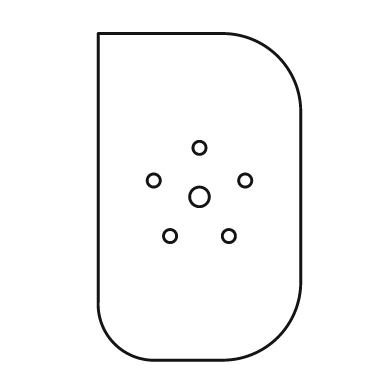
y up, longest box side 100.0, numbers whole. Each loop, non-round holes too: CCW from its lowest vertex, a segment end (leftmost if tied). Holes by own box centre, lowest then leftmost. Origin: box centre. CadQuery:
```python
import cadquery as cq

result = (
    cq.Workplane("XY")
    .moveTo(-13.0, -50.0)
    .lineTo(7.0, -50.0)
    .threePointArc((24.0, -43.0), (31.0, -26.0))
    .lineTo(31.0, 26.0)
    .threePointArc((24.0, 43.0), (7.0, 50.0))
    .lineTo(-31.0, 50.0)
    .lineTo(-31.0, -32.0)
    .threePointArc((-26.0, -45.0), (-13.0, -50.0))
    .close()
    .moveTo(-9.0, -12.0)
    .circle(2.0)
    .moveTo(9.0, -12.0)
    .circle(2.0)
    .moveTo(0.0, 0.0)
    .circle(3.0)
    .moveTo(-14.0, 5.0)
    .circle(2.0)
    .moveTo(14.0, 5.0)
    .circle(2.0)
    .moveTo(0.0, 15.0)
    .circle(2.0)
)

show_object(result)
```